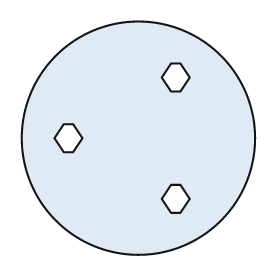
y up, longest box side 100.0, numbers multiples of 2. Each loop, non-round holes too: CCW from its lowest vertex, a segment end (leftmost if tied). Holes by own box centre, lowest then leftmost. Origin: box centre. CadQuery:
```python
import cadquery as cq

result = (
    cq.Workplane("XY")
    .moveTo(0.0, 0.0)
    .circle(50.0)
    .moveTo(14.0, -32.0)
    .lineTo(18.0, -32.0)
    .lineTo(22.0, -26.0)
    .lineTo(18.0, -20.0)
    .lineTo(14.0, -20.0)
    .lineTo(10.0, -26.0)
    .close()
    .moveTo(-32.0, -6.0)
    .lineTo(-28.0, -6.0)
    .lineTo(-24.0, 0.0)
    .lineTo(-28.0, 6.0)
    .lineTo(-32.0, 6.0)
    .lineTo(-36.0, 0.0)
    .close()
    .moveTo(14.0, 20.0)
    .lineTo(18.0, 20.0)
    .lineTo(22.0, 26.0)
    .lineTo(18.0, 32.0)
    .lineTo(14.0, 32.0)
    .lineTo(10.0, 26.0)
    .close()
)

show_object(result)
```